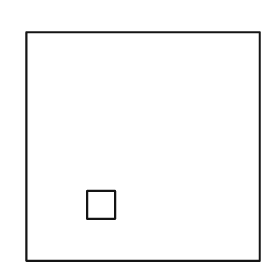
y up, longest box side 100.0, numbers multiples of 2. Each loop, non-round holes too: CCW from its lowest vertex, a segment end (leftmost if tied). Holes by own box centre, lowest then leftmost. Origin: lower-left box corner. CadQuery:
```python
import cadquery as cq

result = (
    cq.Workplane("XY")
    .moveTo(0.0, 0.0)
    .lineTo(100.0, 0.0)
    .lineTo(100.0, 98.0)
    .lineTo(0.0, 98.0)
    .close()
    .moveTo(26.0, 18.0)
    .lineTo(38.0, 18.0)
    .lineTo(38.0, 30.0)
    .lineTo(26.0, 30.0)
    .close()
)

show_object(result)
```